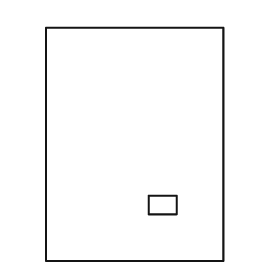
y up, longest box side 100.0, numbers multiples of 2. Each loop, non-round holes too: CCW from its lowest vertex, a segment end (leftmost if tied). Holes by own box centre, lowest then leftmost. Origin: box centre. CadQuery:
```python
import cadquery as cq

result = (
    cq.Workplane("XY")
    .moveTo(-38.0, -50.0)
    .lineTo(38.0, -50.0)
    .lineTo(38.0, 50.0)
    .lineTo(-38.0, 50.0)
    .close()
    .moveTo(6.0, -30.0)
    .lineTo(18.0, -30.0)
    .lineTo(18.0, -22.0)
    .lineTo(6.0, -22.0)
    .close()
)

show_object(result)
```